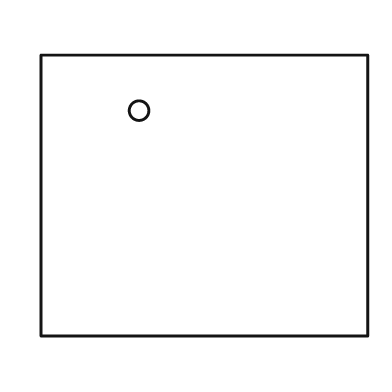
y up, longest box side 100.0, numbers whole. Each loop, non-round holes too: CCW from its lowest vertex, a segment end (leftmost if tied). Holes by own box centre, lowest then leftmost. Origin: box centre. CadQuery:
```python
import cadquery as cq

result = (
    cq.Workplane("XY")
    .moveTo(-50.0, -43.0)
    .lineTo(50.0, -43.0)
    .lineTo(50.0, 43.0)
    .lineTo(-50.0, 43.0)
    .close()
    .moveTo(-20.0, 26.0)
    .circle(3.0)
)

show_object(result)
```